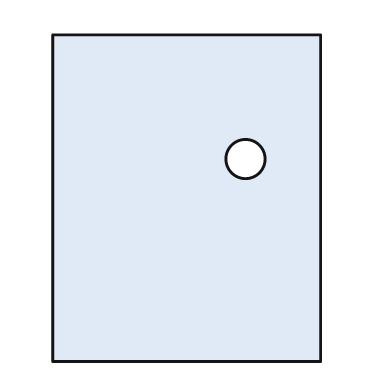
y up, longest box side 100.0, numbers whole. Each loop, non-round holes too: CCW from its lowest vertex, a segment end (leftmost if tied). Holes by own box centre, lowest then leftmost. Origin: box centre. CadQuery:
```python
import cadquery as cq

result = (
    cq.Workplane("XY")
    .moveTo(-41.0, -50.0)
    .lineTo(41.0, -50.0)
    .lineTo(41.0, 50.0)
    .lineTo(-41.0, 50.0)
    .close()
    .moveTo(18.0, 12.0)
    .circle(6.0)
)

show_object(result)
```